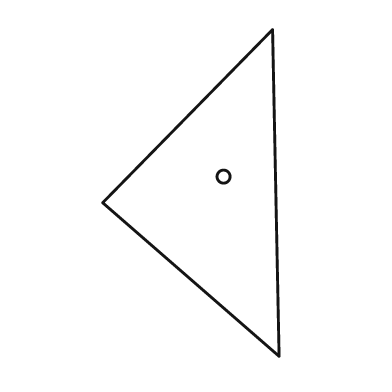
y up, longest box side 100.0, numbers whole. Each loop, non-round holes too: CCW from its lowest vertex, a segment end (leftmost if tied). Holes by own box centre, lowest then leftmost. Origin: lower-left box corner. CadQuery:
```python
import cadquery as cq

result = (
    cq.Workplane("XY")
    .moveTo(54.0, 0.0)
    .lineTo(52.0, 100.0)
    .lineTo(0.0, 47.0)
    .close()
    .moveTo(37.0, 55.0)
    .circle(2.0)
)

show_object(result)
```